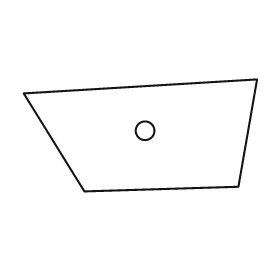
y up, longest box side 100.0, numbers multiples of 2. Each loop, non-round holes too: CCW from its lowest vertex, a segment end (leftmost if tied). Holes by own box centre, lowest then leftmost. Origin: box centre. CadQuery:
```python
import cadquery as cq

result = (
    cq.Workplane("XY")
    .moveTo(-24.0, -24.0)
    .lineTo(42.0, -22.0)
    .lineTo(50.0, 24.0)
    .lineTo(-50.0, 18.0)
    .close()
    .moveTo(2.0, 2.0)
    .circle(4.0)
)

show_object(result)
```